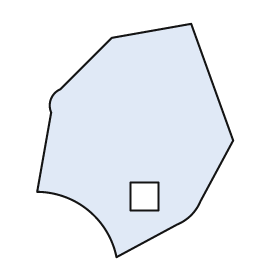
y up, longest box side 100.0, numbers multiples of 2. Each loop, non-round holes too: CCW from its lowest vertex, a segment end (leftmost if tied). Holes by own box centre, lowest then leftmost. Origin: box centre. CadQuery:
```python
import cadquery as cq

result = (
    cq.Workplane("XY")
    .moveTo(-8.0, -50.0)
    .lineTo(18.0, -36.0)
    .threePointArc((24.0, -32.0), (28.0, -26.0))
    .lineTo(42.0, 0.0)
    .lineTo(24.0, 50.0)
    .lineTo(-10.0, 44.0)
    .lineTo(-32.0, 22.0)
    .threePointArc((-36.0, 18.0), (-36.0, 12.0))
    .lineTo(-42.0, -22.0)
    .threePointArc((-20.0, -30.0), (-8.0, -50.0))
    .close()
    .moveTo(-2.0, -30.0)
    .lineTo(10.0, -30.0)
    .lineTo(10.0, -18.0)
    .lineTo(-2.0, -18.0)
    .close()
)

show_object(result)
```